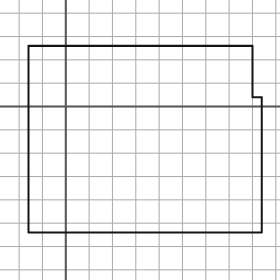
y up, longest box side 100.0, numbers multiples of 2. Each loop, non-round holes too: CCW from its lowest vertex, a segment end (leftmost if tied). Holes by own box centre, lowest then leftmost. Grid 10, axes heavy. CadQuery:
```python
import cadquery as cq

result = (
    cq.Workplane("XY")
    .moveTo(-16.0, -54.0)
    .lineTo(84.0, -54.0)
    .lineTo(84.0, 4.0)
    .lineTo(80.0, 4.0)
    .lineTo(80.0, 26.0)
    .lineTo(-16.0, 26.0)
    .close()
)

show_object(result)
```